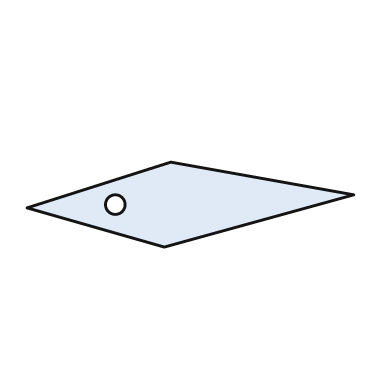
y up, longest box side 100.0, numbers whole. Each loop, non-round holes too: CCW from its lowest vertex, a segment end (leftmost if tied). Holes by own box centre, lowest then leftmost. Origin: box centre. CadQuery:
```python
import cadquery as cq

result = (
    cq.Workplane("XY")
    .moveTo(-8.0, -13.0)
    .lineTo(50.0, 3.0)
    .lineTo(-6.0, 13.0)
    .lineTo(-50.0, -1.0)
    .close()
    .moveTo(-23.0, 0.0)
    .circle(3.0)
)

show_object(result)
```